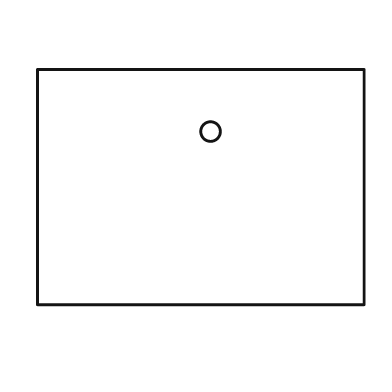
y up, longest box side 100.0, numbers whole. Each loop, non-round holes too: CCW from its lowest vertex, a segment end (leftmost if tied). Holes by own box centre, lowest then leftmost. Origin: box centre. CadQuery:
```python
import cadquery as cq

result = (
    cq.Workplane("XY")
    .moveTo(-50.0, -36.0)
    .lineTo(50.0, -36.0)
    .lineTo(50.0, 36.0)
    .lineTo(-50.0, 36.0)
    .close()
    .moveTo(3.0, 17.0)
    .circle(3.0)
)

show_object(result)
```